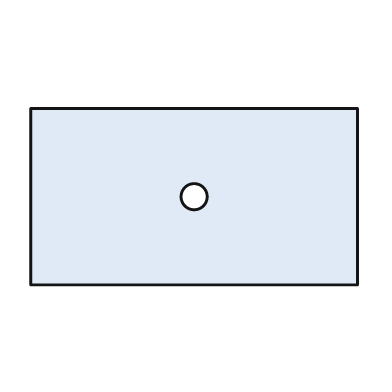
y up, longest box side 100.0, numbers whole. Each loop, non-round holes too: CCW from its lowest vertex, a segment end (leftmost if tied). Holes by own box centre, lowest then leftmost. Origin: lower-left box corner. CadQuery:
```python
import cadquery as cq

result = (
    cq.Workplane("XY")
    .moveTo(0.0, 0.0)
    .lineTo(100.0, 0.0)
    .lineTo(100.0, 54.0)
    .lineTo(0.0, 54.0)
    .close()
    .moveTo(50.0, 27.0)
    .circle(4.0)
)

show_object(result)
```